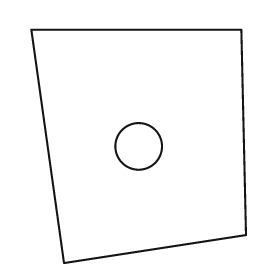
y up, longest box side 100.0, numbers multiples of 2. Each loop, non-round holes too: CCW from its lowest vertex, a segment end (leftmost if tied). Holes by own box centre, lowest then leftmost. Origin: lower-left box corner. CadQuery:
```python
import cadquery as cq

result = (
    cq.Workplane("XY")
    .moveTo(14.0, 0.0)
    .lineTo(92.0, 12.0)
    .lineTo(90.0, 100.0)
    .lineTo(0.0, 100.0)
    .close()
    .moveTo(46.0, 50.0)
    .circle(10.0)
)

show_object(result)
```